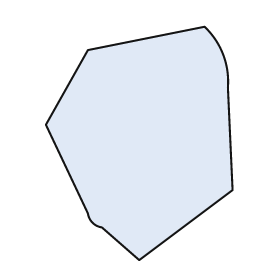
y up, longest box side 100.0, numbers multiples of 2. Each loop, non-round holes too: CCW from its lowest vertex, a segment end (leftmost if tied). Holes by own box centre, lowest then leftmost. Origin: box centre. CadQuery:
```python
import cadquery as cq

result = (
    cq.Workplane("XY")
    .moveTo(0.0, -50.0)
    .lineTo(40.0, -20.0)
    .lineTo(38.0, 24.0)
    .threePointArc((36.0, 38.0), (28.0, 50.0))
    .lineTo(-22.0, 40.0)
    .lineTo(-40.0, 8.0)
    .lineTo(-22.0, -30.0)
    .threePointArc((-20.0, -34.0), (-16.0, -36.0))
    .close()
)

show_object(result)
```